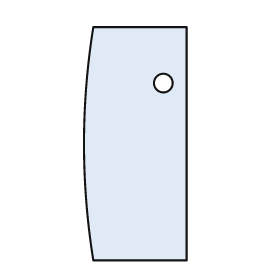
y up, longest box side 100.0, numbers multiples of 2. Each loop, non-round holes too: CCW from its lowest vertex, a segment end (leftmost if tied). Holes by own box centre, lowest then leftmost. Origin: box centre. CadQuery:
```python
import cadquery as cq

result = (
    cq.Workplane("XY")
    .moveTo(-18.0, -50.0)
    .lineTo(22.0, -50.0)
    .lineTo(22.0, 50.0)
    .lineTo(-18.0, 50.0)
    .threePointArc((-22.0, 0.0), (-18.0, -50.0))
    .close()
    .moveTo(12.0, 26.0)
    .circle(4.0)
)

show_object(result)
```